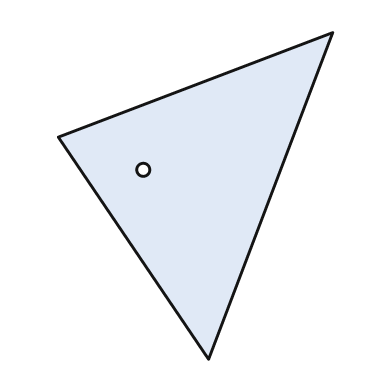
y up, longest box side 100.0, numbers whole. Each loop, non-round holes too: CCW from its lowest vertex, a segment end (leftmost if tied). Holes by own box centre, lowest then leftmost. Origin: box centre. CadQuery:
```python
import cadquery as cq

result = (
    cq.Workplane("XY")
    .moveTo(4.0, -50.0)
    .lineTo(42.0, 50.0)
    .lineTo(-42.0, 18.0)
    .close()
    .moveTo(-16.0, 8.0)
    .circle(2.0)
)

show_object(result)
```